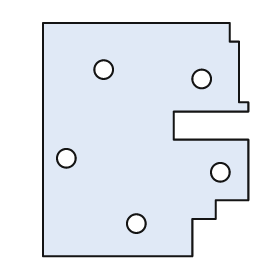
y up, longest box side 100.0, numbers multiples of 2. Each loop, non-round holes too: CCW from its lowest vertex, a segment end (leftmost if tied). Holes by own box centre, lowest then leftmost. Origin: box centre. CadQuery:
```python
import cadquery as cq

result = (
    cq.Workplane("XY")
    .moveTo(-44.0, -50.0)
    .lineTo(20.0, -50.0)
    .lineTo(20.0, -34.0)
    .lineTo(30.0, -34.0)
    .lineTo(30.0, -26.0)
    .lineTo(44.0, -26.0)
    .lineTo(44.0, 0.0)
    .lineTo(12.0, 0.0)
    .lineTo(12.0, 12.0)
    .lineTo(44.0, 12.0)
    .lineTo(44.0, 16.0)
    .lineTo(40.0, 16.0)
    .lineTo(40.0, 42.0)
    .lineTo(36.0, 42.0)
    .lineTo(36.0, 50.0)
    .lineTo(-44.0, 50.0)
    .close()
    .moveTo(-4.0, -36.0)
    .circle(4.0)
    .moveTo(32.0, -14.0)
    .circle(4.0)
    .moveTo(-34.0, -8.0)
    .circle(4.0)
    .moveTo(24.0, 26.0)
    .circle(4.0)
    .moveTo(-18.0, 30.0)
    .circle(4.0)
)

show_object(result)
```